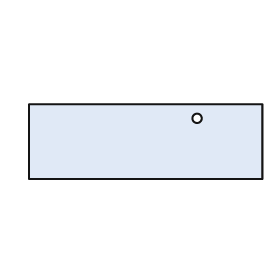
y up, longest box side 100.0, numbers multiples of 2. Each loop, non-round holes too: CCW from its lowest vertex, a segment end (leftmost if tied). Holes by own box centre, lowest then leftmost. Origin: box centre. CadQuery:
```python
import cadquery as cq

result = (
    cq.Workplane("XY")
    .moveTo(-50.0, -16.0)
    .lineTo(50.0, -16.0)
    .lineTo(50.0, 16.0)
    .lineTo(-50.0, 16.0)
    .close()
    .moveTo(22.0, 10.0)
    .circle(2.0)
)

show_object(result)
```